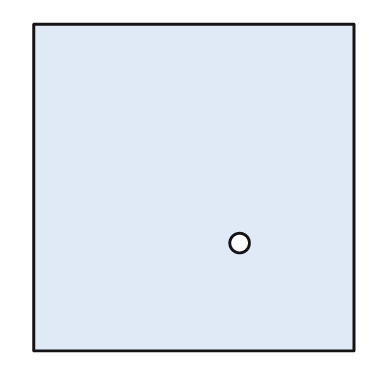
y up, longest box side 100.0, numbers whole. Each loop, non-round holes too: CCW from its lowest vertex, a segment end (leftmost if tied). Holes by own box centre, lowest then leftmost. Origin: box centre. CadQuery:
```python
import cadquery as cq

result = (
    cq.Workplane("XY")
    .moveTo(-49.0, -50.0)
    .lineTo(49.0, -50.0)
    .lineTo(49.0, 50.0)
    .lineTo(-49.0, 50.0)
    .close()
    .moveTo(14.0, -17.0)
    .circle(3.0)
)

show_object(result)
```